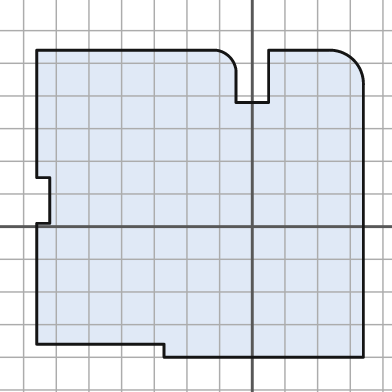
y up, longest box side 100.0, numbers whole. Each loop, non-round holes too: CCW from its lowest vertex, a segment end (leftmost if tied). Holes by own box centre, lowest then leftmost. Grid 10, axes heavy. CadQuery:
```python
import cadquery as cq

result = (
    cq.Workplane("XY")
    .moveTo(-27.0, -40.0)
    .lineTo(34.0, -40.0)
    .lineTo(34.0, 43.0)
    .threePointArc((31.0, 51.0), (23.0, 54.0))
    .lineTo(5.0, 54.0)
    .lineTo(5.0, 38.0)
    .lineTo(-5.0, 38.0)
    .lineTo(-5.0, 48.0)
    .threePointArc((-7.0, 52.0), (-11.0, 54.0))
    .lineTo(-66.0, 54.0)
    .lineTo(-66.0, 15.0)
    .lineTo(-62.0, 15.0)
    .lineTo(-62.0, 1.0)
    .lineTo(-66.0, 1.0)
    .lineTo(-66.0, -36.0)
    .lineTo(-27.0, -36.0)
    .close()
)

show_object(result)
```